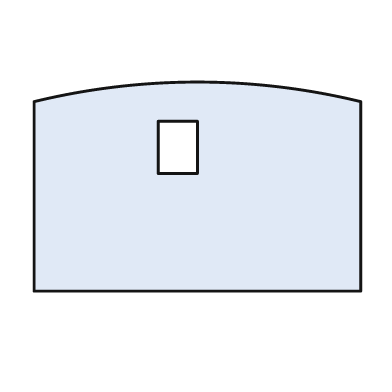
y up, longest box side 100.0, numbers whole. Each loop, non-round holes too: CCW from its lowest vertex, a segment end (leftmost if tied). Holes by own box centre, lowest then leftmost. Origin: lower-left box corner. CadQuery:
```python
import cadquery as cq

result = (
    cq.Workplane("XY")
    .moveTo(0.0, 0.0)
    .lineTo(100.0, 0.0)
    .lineTo(100.0, 58.0)
    .threePointArc((50.0, 64.0), (0.0, 58.0))
    .close()
    .moveTo(38.0, 36.0)
    .lineTo(50.0, 36.0)
    .lineTo(50.0, 52.0)
    .lineTo(38.0, 52.0)
    .close()
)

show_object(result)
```